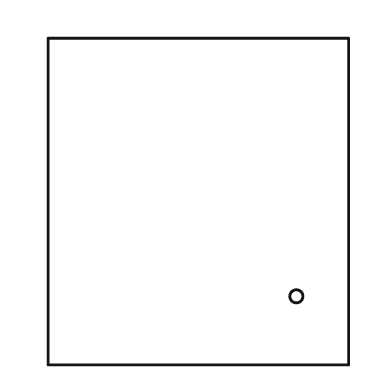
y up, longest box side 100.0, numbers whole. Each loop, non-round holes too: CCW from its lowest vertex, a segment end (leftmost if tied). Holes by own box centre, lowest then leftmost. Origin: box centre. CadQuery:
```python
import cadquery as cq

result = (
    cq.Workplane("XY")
    .moveTo(-46.0, -50.0)
    .lineTo(46.0, -50.0)
    .lineTo(46.0, 50.0)
    .lineTo(-46.0, 50.0)
    .close()
    .moveTo(30.0, -29.0)
    .circle(2.0)
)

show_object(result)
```